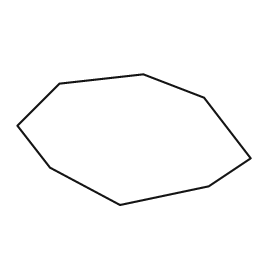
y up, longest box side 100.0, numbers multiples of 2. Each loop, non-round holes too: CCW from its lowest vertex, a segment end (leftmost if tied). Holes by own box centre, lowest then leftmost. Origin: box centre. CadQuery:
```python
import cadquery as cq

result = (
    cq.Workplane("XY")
    .moveTo(-6.0, -28.0)
    .lineTo(32.0, -20.0)
    .lineTo(50.0, -8.0)
    .lineTo(30.0, 18.0)
    .lineTo(4.0, 28.0)
    .lineTo(-32.0, 24.0)
    .lineTo(-50.0, 6.0)
    .lineTo(-36.0, -12.0)
    .close()
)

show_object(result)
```